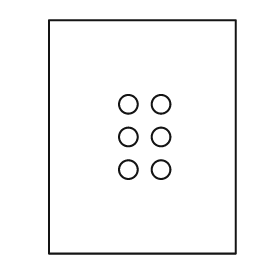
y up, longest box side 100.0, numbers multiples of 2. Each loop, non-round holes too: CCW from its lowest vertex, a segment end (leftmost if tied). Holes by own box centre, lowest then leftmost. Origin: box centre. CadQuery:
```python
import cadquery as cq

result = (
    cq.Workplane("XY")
    .moveTo(-40.0, -50.0)
    .lineTo(40.0, -50.0)
    .lineTo(40.0, 50.0)
    .lineTo(-40.0, 50.0)
    .close()
    .moveTo(-6.0, -14.0)
    .circle(4.0)
    .moveTo(8.0, -14.0)
    .circle(4.0)
    .moveTo(-6.0, 0.0)
    .circle(4.0)
    .moveTo(8.0, 0.0)
    .circle(4.0)
    .moveTo(-6.0, 14.0)
    .circle(4.0)
    .moveTo(8.0, 14.0)
    .circle(4.0)
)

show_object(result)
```